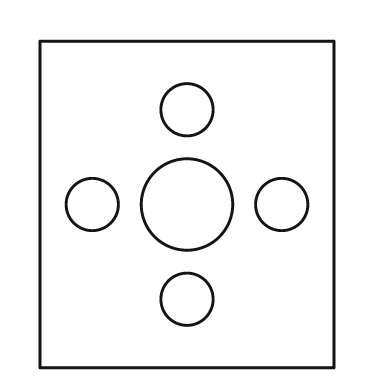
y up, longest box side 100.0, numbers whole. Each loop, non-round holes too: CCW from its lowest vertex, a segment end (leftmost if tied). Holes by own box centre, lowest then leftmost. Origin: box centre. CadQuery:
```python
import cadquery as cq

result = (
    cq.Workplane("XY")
    .moveTo(-45.0, -50.0)
    .lineTo(45.0, -50.0)
    .lineTo(45.0, 50.0)
    .lineTo(-45.0, 50.0)
    .close()
    .moveTo(0.0, -29.0)
    .circle(8.0)
    .moveTo(-29.0, 0.0)
    .circle(8.0)
    .moveTo(0.0, 0.0)
    .circle(14.0)
    .moveTo(29.0, 0.0)
    .circle(8.0)
    .moveTo(0.0, 29.0)
    .circle(8.0)
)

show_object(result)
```